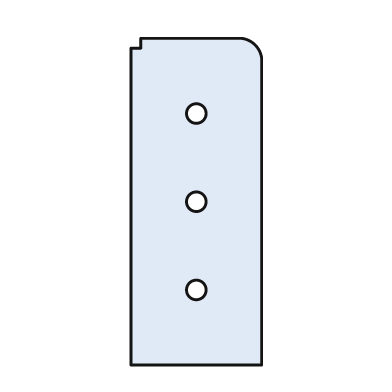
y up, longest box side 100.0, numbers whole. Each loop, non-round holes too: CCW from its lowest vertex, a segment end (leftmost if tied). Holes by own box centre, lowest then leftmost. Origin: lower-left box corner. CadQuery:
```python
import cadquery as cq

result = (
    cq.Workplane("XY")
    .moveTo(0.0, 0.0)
    .lineTo(40.0, 0.0)
    .lineTo(40.0, 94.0)
    .threePointArc((38.0, 98.0), (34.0, 100.0))
    .lineTo(3.0, 100.0)
    .lineTo(3.0, 97.0)
    .lineTo(0.0, 97.0)
    .close()
    .moveTo(20.0, 23.0)
    .circle(3.0)
    .moveTo(20.0, 50.0)
    .circle(3.0)
    .moveTo(20.0, 77.0)
    .circle(3.0)
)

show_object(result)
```